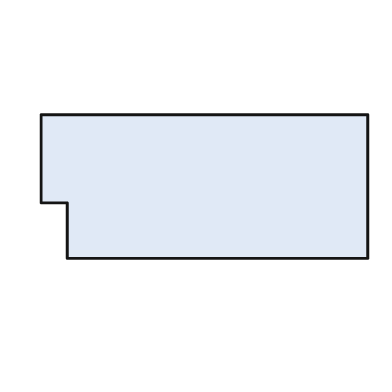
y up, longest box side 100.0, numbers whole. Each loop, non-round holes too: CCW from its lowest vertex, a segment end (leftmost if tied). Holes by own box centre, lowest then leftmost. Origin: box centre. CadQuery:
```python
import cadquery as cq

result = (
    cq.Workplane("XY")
    .moveTo(-42.0, -22.0)
    .lineTo(50.0, -22.0)
    .lineTo(50.0, 22.0)
    .lineTo(-50.0, 22.0)
    .lineTo(-50.0, -5.0)
    .lineTo(-42.0, -5.0)
    .close()
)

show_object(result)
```